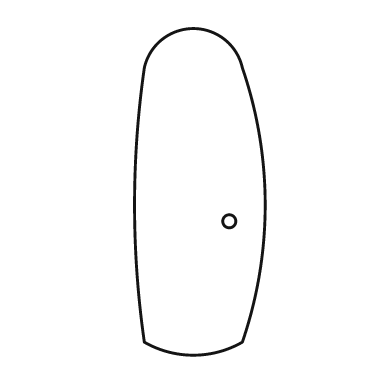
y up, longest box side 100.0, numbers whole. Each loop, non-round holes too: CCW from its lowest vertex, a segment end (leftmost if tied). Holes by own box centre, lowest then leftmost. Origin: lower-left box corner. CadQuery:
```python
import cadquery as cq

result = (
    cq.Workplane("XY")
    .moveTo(3.0, 4.0)
    .threePointArc((18.0, 0.0), (33.0, 4.0))
    .threePointArc((40.0, 46.0), (33.0, 88.0))
    .threePointArc((18.0, 100.0), (3.0, 88.0))
    .threePointArc((0.0, 46.0), (3.0, 4.0))
    .close()
    .moveTo(29.0, 41.0)
    .circle(2.0)
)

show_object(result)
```